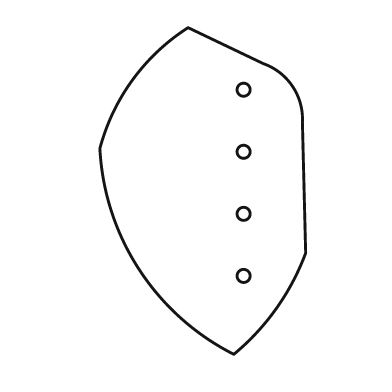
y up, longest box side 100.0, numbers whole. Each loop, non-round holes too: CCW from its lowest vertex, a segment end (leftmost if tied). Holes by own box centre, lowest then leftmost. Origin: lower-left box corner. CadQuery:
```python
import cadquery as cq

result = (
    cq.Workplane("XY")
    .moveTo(41.0, 0.0)
    .threePointArc((54.0, 14.0), (63.0, 31.0))
    .lineTo(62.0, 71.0)
    .threePointArc((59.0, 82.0), (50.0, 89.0))
    .lineTo(27.0, 100.0)
    .threePointArc((10.0, 84.0), (0.0, 63.0))
    .threePointArc((12.0, 26.0), (41.0, 0.0))
    .close()
    .moveTo(44.0, 24.0)
    .circle(2.0)
    .moveTo(44.0, 43.0)
    .circle(2.0)
    .moveTo(44.0, 62.0)
    .circle(2.0)
    .moveTo(44.0, 81.0)
    .circle(2.0)
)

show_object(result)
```